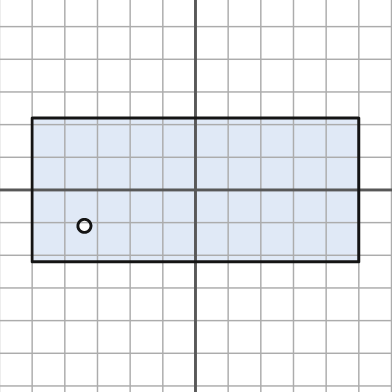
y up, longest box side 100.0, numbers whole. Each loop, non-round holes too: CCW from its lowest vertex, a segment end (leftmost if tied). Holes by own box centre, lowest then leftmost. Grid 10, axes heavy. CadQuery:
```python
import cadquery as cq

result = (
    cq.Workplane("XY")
    .moveTo(-50.0, -22.0)
    .lineTo(50.0, -22.0)
    .lineTo(50.0, 22.0)
    .lineTo(-50.0, 22.0)
    .close()
    .moveTo(-34.0, -11.0)
    .circle(2.0)
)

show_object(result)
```